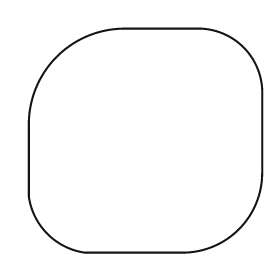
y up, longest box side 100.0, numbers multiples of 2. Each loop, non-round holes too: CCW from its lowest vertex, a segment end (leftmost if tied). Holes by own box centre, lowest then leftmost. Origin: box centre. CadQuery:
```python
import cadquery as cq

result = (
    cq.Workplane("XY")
    .moveTo(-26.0, -48.0)
    .lineTo(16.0, -48.0)
    .threePointArc((40.0, -38.0), (50.0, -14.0))
    .lineTo(50.0, 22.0)
    .threePointArc((42.0, 40.0), (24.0, 48.0))
    .lineTo(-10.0, 48.0)
    .threePointArc((-38.0, 36.0), (-50.0, 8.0))
    .lineTo(-50.0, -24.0)
    .threePointArc((-42.0, -40.0), (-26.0, -48.0))
    .close()
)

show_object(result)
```